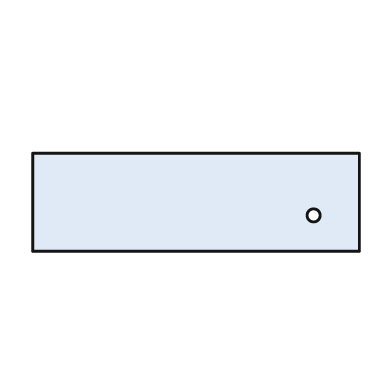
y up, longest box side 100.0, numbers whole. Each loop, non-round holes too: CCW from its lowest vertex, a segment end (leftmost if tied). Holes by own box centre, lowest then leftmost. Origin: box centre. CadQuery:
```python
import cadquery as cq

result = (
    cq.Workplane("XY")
    .moveTo(-50.0, -15.0)
    .lineTo(50.0, -15.0)
    .lineTo(50.0, 15.0)
    .lineTo(-50.0, 15.0)
    .close()
    .moveTo(36.0, -4.0)
    .circle(2.0)
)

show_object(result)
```